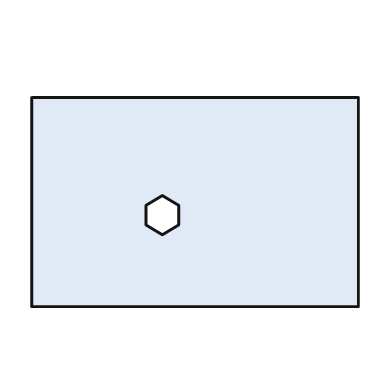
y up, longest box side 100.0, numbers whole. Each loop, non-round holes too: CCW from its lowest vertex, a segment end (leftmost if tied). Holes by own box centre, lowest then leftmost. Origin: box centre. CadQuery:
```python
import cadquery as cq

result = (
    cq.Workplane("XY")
    .moveTo(-50.0, -32.0)
    .lineTo(50.0, -32.0)
    .lineTo(50.0, 32.0)
    .lineTo(-50.0, 32.0)
    .close()
    .moveTo(-10.0, -10.0)
    .lineTo(-5.0, -7.0)
    .lineTo(-5.0, -1.0)
    .lineTo(-10.0, 2.0)
    .lineTo(-15.0, -1.0)
    .lineTo(-15.0, -7.0)
    .close()
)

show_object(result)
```